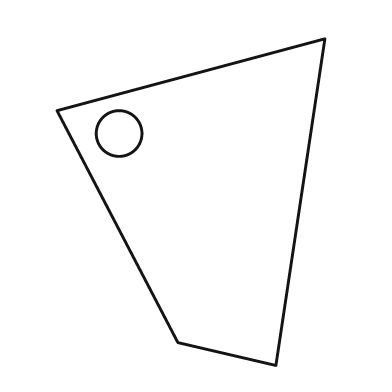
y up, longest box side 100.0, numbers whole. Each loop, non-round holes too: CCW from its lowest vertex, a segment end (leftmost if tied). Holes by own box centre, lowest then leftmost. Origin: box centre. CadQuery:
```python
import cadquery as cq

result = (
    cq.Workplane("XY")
    .moveTo(26.0, -50.0)
    .lineTo(41.0, 50.0)
    .lineTo(-41.0, 28.0)
    .lineTo(-4.0, -43.0)
    .close()
    .moveTo(-22.0, 21.0)
    .circle(7.0)
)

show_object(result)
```